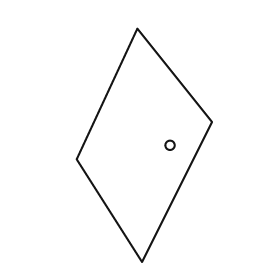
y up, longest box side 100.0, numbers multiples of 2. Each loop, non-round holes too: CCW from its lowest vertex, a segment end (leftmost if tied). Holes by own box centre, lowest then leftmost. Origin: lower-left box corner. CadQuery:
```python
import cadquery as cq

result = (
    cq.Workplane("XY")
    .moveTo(28.0, 0.0)
    .lineTo(58.0, 60.0)
    .lineTo(26.0, 100.0)
    .lineTo(0.0, 44.0)
    .close()
    .moveTo(40.0, 50.0)
    .circle(2.0)
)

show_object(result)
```